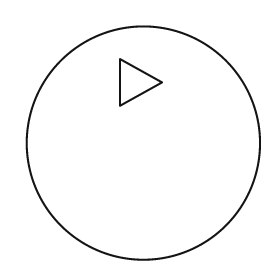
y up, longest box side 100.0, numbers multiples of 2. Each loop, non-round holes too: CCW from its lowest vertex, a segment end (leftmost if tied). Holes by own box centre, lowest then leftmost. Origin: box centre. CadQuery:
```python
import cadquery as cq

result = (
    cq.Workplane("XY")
    .moveTo(0.0, 0.0)
    .circle(50.0)
    .moveTo(-10.0, 16.0)
    .lineTo(8.0, 26.0)
    .lineTo(-10.0, 36.0)
    .close()
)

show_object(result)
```